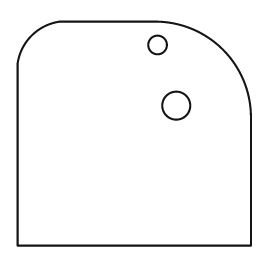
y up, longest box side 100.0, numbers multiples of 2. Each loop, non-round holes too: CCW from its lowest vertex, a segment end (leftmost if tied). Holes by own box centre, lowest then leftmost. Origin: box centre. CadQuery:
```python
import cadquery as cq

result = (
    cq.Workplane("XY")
    .moveTo(-50.0, -48.0)
    .lineTo(50.0, -48.0)
    .lineTo(50.0, 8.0)
    .threePointArc((38.0, 36.0), (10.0, 48.0))
    .lineTo(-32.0, 48.0)
    .threePointArc((-44.0, 42.0), (-50.0, 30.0))
    .close()
    .moveTo(18.0, 12.0)
    .circle(6.0)
    .moveTo(10.0, 38.0)
    .circle(4.0)
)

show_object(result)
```